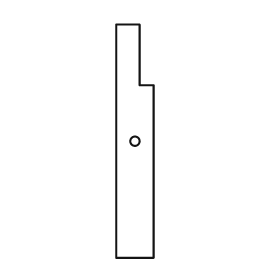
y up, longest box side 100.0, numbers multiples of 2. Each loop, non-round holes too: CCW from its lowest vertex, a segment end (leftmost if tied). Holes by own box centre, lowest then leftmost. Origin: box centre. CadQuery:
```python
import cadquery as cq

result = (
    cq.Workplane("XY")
    .moveTo(-8.0, -50.0)
    .lineTo(8.0, -50.0)
    .lineTo(8.0, 24.0)
    .lineTo(2.0, 24.0)
    .lineTo(2.0, 50.0)
    .lineTo(-8.0, 50.0)
    .close()
    .moveTo(0.0, 0.0)
    .circle(2.0)
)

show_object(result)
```